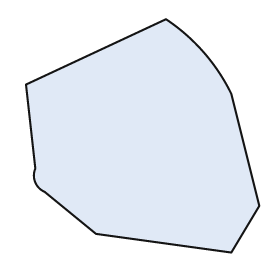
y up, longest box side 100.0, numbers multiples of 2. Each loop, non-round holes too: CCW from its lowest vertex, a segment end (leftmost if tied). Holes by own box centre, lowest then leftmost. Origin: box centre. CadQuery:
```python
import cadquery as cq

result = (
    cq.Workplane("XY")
    .moveTo(38.0, -50.0)
    .lineTo(50.0, -30.0)
    .lineTo(38.0, 18.0)
    .threePointArc((26.0, 36.0), (10.0, 50.0))
    .lineTo(-50.0, 22.0)
    .lineTo(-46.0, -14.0)
    .threePointArc((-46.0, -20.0), (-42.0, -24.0))
    .lineTo(-20.0, -42.0)
    .close()
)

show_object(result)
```